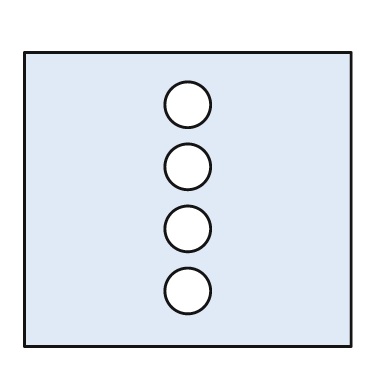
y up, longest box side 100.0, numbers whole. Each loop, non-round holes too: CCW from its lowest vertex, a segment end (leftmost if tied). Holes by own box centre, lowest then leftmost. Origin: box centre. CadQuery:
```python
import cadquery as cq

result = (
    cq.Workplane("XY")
    .moveTo(-50.0, -45.0)
    .lineTo(50.0, -45.0)
    .lineTo(50.0, 45.0)
    .lineTo(-50.0, 45.0)
    .close()
    .moveTo(0.0, -28.0)
    .circle(7.0)
    .moveTo(0.0, -9.0)
    .circle(7.0)
    .moveTo(0.0, 10.0)
    .circle(7.0)
    .moveTo(0.0, 29.0)
    .circle(7.0)
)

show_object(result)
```